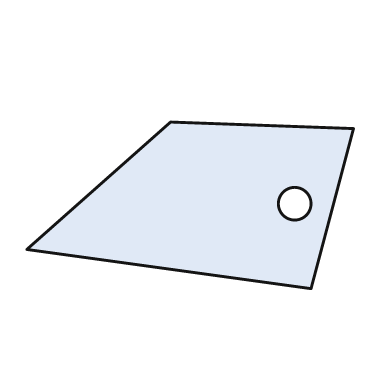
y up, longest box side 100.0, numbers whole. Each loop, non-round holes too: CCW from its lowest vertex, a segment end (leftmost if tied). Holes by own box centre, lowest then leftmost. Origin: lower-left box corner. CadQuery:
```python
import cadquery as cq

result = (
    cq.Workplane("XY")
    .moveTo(87.0, 0.0)
    .lineTo(100.0, 49.0)
    .lineTo(44.0, 51.0)
    .lineTo(0.0, 12.0)
    .close()
    .moveTo(82.0, 26.0)
    .circle(5.0)
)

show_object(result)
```